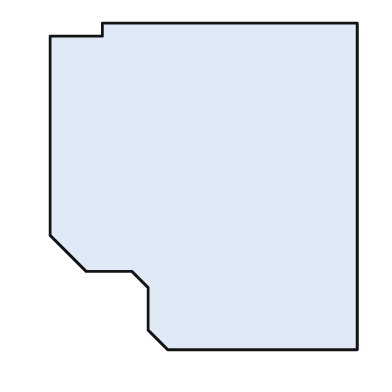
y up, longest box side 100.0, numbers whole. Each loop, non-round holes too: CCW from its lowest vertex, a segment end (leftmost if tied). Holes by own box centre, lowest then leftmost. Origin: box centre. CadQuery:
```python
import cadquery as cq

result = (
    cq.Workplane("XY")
    .moveTo(-11.0, -50.0)
    .lineTo(47.0, -50.0)
    .lineTo(47.0, 50.0)
    .lineTo(-31.0, 50.0)
    .lineTo(-31.0, 46.0)
    .lineTo(-47.0, 46.0)
    .lineTo(-47.0, -15.0)
    .lineTo(-36.0, -26.0)
    .lineTo(-22.0, -26.0)
    .lineTo(-17.0, -31.0)
    .lineTo(-17.0, -44.0)
    .close()
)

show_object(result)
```